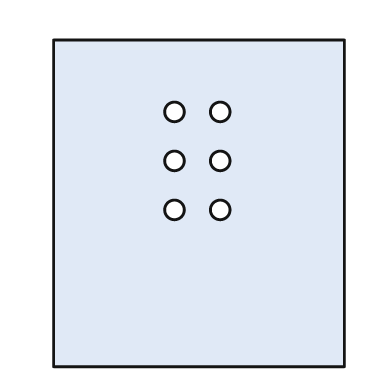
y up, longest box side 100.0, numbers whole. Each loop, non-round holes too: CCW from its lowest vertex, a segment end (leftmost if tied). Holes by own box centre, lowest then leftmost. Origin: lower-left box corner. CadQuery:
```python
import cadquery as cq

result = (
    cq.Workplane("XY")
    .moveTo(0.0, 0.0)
    .lineTo(89.0, 0.0)
    .lineTo(89.0, 100.0)
    .lineTo(0.0, 100.0)
    .close()
    .moveTo(37.0, 48.0)
    .circle(3.0)
    .moveTo(51.0, 48.0)
    .circle(3.0)
    .moveTo(37.0, 63.0)
    .circle(3.0)
    .moveTo(51.0, 63.0)
    .circle(3.0)
    .moveTo(37.0, 78.0)
    .circle(3.0)
    .moveTo(51.0, 78.0)
    .circle(3.0)
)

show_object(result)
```